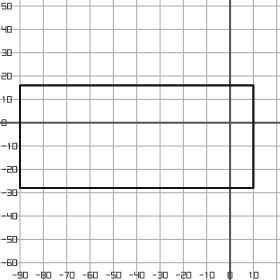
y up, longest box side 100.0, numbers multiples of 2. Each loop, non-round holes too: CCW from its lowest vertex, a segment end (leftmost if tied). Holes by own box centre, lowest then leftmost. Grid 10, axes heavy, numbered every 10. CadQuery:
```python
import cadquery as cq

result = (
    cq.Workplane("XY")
    .moveTo(-90.0, -28.0)
    .lineTo(10.0, -28.0)
    .lineTo(10.0, 16.0)
    .lineTo(-90.0, 16.0)
    .close()
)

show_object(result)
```